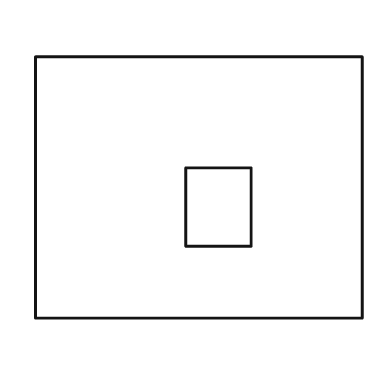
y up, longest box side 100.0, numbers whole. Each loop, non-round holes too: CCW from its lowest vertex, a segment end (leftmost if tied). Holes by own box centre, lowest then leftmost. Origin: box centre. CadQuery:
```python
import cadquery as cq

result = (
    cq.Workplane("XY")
    .moveTo(-50.0, -40.0)
    .lineTo(50.0, -40.0)
    .lineTo(50.0, 40.0)
    .lineTo(-50.0, 40.0)
    .close()
    .moveTo(-4.0, -18.0)
    .lineTo(16.0, -18.0)
    .lineTo(16.0, 6.0)
    .lineTo(-4.0, 6.0)
    .close()
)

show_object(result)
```